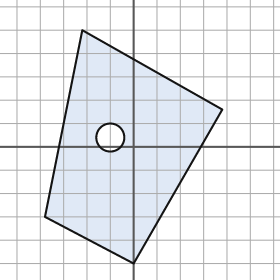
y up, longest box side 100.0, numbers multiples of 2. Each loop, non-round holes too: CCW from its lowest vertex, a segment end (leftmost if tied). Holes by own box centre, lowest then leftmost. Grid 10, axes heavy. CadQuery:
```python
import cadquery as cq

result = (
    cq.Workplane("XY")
    .moveTo(0.0, -50.0)
    .lineTo(38.0, 16.0)
    .lineTo(-22.0, 50.0)
    .lineTo(-38.0, -30.0)
    .close()
    .moveTo(-10.0, 4.0)
    .circle(6.0)
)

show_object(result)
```